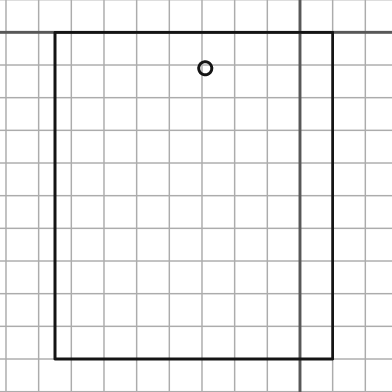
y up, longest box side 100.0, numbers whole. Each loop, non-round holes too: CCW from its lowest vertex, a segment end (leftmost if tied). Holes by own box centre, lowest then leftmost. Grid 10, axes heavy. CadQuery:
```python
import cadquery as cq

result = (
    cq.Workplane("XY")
    .moveTo(-75.0, -100.0)
    .lineTo(10.0, -100.0)
    .lineTo(10.0, 0.0)
    .lineTo(-75.0, 0.0)
    .close()
    .moveTo(-29.0, -11.0)
    .circle(2.0)
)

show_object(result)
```